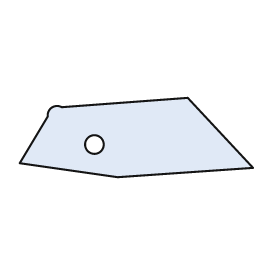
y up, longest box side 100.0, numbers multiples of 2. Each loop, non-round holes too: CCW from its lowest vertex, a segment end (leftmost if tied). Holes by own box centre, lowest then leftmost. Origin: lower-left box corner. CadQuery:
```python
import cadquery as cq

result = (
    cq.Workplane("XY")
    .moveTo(42.0, 0.0)
    .lineTo(100.0, 4.0)
    .lineTo(72.0, 34.0)
    .lineTo(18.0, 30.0)
    .threePointArc((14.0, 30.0), (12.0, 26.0))
    .lineTo(0.0, 6.0)
    .close()
    .moveTo(32.0, 14.0)
    .circle(4.0)
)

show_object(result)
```